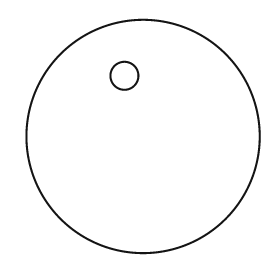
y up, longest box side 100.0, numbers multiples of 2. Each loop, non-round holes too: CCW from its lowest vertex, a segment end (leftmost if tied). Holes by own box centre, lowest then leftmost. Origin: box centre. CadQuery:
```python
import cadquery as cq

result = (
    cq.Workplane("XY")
    .moveTo(0.0, 0.0)
    .circle(50.0)
    .moveTo(-8.0, 26.0)
    .circle(6.0)
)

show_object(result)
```